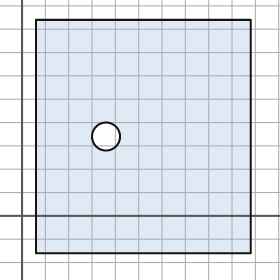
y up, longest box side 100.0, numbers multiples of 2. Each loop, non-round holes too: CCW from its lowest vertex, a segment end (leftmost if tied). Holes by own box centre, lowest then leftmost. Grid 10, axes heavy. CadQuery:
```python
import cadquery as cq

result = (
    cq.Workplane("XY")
    .moveTo(6.0, -16.0)
    .lineTo(98.0, -16.0)
    .lineTo(98.0, 84.0)
    .lineTo(6.0, 84.0)
    .close()
    .moveTo(36.0, 34.0)
    .circle(6.0)
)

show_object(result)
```